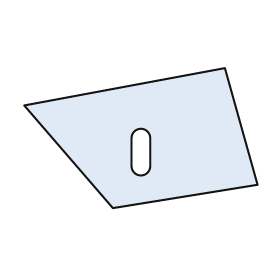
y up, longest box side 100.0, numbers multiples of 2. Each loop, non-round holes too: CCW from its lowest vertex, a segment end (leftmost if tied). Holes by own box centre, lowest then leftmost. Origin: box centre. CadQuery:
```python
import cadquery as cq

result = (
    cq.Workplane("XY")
    .moveTo(-12.0, -30.0)
    .lineTo(50.0, -20.0)
    .lineTo(36.0, 30.0)
    .lineTo(-50.0, 14.0)
    .close()
    .moveTo(-4.0, -12.0)
    .threePointArc((0.0, -16.0), (4.0, -12.0))
    .lineTo(4.0, 0.0)
    .threePointArc((0.0, 4.0), (-4.0, 0.0))
    .close()
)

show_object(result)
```